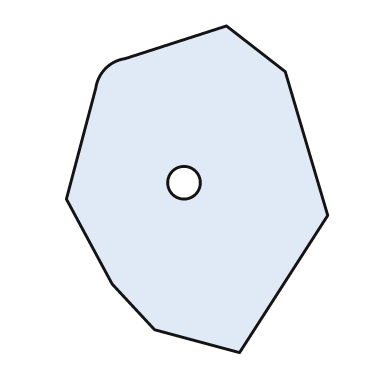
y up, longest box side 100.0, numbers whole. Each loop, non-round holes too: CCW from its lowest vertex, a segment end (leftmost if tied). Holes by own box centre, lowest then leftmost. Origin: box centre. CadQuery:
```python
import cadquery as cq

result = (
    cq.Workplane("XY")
    .moveTo(13.0, -50.0)
    .lineTo(40.0, -8.0)
    .lineTo(27.0, 36.0)
    .lineTo(9.0, 50.0)
    .lineTo(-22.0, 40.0)
    .threePointArc((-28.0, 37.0), (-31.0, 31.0))
    .lineTo(-40.0, -3.0)
    .lineTo(-26.0, -29.0)
    .lineTo(-13.0, -43.0)
    .close()
    .moveTo(-4.0, 2.0)
    .circle(5.0)
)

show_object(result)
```